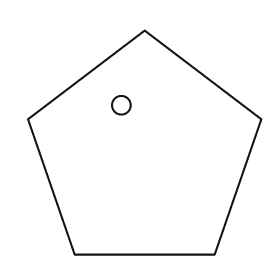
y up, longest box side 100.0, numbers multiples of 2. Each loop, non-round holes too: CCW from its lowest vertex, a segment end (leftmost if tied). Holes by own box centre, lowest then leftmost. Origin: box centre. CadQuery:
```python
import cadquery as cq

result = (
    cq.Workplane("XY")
    .moveTo(-30.0, -48.0)
    .lineTo(30.0, -48.0)
    .lineTo(50.0, 10.0)
    .lineTo(0.0, 48.0)
    .lineTo(-50.0, 10.0)
    .close()
    .moveTo(-10.0, 16.0)
    .circle(4.0)
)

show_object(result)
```